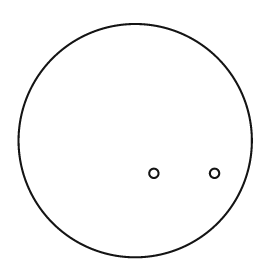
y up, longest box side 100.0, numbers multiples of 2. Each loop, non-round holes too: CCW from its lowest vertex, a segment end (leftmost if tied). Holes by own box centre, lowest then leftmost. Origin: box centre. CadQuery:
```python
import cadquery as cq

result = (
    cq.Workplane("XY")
    .moveTo(0.0, 0.0)
    .circle(50.0)
    .moveTo(8.0, -14.0)
    .circle(2.0)
    .moveTo(34.0, -14.0)
    .circle(2.0)
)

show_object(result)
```